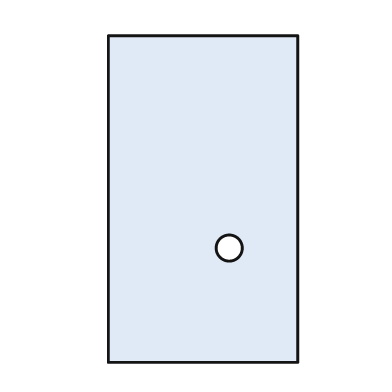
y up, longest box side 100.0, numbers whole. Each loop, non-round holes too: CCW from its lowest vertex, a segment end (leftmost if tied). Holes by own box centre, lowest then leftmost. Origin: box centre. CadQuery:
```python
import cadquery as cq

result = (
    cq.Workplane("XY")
    .moveTo(-29.0, -50.0)
    .lineTo(29.0, -50.0)
    .lineTo(29.0, 50.0)
    .lineTo(-29.0, 50.0)
    .close()
    .moveTo(8.0, -15.0)
    .circle(4.0)
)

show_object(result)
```